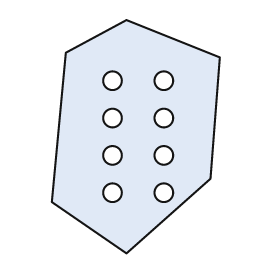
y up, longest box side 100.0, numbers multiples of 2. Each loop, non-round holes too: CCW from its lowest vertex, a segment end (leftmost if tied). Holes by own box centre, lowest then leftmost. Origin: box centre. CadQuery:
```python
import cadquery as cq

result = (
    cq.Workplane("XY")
    .moveTo(-4.0, -50.0)
    .lineTo(32.0, -18.0)
    .lineTo(36.0, 34.0)
    .lineTo(-4.0, 50.0)
    .lineTo(-30.0, 36.0)
    .lineTo(-36.0, -28.0)
    .close()
    .moveTo(-10.0, -24.0)
    .circle(4.0)
    .moveTo(12.0, -24.0)
    .circle(4.0)
    .moveTo(-10.0, -8.0)
    .circle(4.0)
    .moveTo(12.0, -8.0)
    .circle(4.0)
    .moveTo(-10.0, 8.0)
    .circle(4.0)
    .moveTo(12.0, 8.0)
    .circle(4.0)
    .moveTo(-10.0, 24.0)
    .circle(4.0)
    .moveTo(12.0, 24.0)
    .circle(4.0)
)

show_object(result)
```